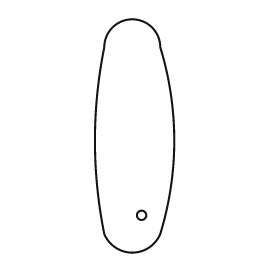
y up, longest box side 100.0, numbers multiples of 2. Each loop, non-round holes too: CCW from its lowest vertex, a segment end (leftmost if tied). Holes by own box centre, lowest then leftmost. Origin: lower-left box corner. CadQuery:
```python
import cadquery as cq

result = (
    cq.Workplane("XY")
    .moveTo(4.0, 8.0)
    .threePointArc((16.0, 0.0), (28.0, 8.0))
    .threePointArc((34.0, 48.0), (28.0, 88.0))
    .threePointArc((16.0, 100.0), (4.0, 88.0))
    .threePointArc((0.0, 48.0), (4.0, 8.0))
    .close()
    .moveTo(20.0, 16.0)
    .circle(2.0)
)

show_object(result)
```